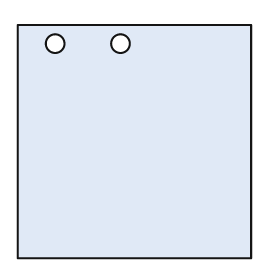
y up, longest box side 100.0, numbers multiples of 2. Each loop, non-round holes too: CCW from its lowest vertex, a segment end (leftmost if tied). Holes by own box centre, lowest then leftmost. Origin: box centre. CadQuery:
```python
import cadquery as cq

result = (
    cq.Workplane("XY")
    .moveTo(-50.0, -50.0)
    .lineTo(50.0, -50.0)
    .lineTo(50.0, 50.0)
    .lineTo(-50.0, 50.0)
    .close()
    .moveTo(-34.0, 42.0)
    .circle(4.0)
    .moveTo(-6.0, 42.0)
    .circle(4.0)
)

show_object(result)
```